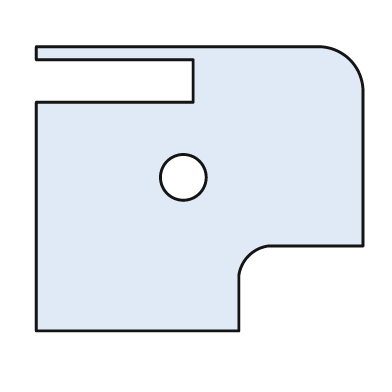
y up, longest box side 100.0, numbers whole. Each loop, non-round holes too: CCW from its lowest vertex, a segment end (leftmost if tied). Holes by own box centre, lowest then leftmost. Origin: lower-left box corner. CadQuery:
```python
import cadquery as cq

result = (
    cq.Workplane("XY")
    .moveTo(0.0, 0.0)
    .lineTo(62.0, 0.0)
    .lineTo(62.0, 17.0)
    .threePointArc((65.0, 23.0), (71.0, 26.0))
    .lineTo(100.0, 26.0)
    .lineTo(100.0, 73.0)
    .threePointArc((96.0, 83.0), (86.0, 87.0))
    .lineTo(0.0, 87.0)
    .lineTo(0.0, 83.0)
    .lineTo(48.0, 83.0)
    .lineTo(48.0, 70.0)
    .lineTo(0.0, 70.0)
    .close()
    .moveTo(45.0, 47.0)
    .circle(7.0)
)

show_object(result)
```